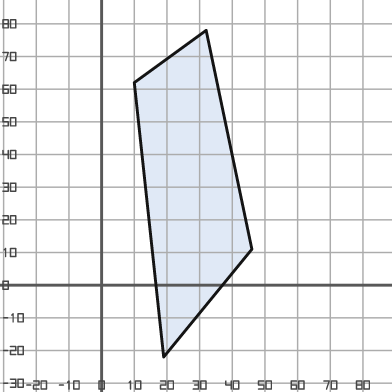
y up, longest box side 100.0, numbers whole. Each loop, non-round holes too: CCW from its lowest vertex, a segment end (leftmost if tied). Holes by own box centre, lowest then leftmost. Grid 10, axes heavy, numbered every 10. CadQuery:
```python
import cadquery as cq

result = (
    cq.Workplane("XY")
    .moveTo(19.0, -22.0)
    .lineTo(46.0, 11.0)
    .lineTo(32.0, 78.0)
    .lineTo(10.0, 62.0)
    .close()
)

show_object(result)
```